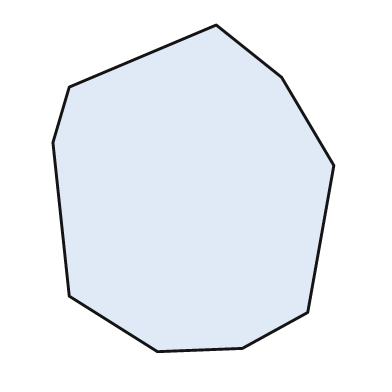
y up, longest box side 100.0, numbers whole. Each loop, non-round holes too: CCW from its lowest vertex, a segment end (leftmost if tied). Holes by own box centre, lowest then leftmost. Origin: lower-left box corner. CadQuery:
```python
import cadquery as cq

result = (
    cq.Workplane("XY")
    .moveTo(32.0, 0.0)
    .lineTo(58.0, 1.0)
    .lineTo(78.0, 12.0)
    .lineTo(86.0, 57.0)
    .lineTo(70.0, 84.0)
    .lineTo(50.0, 100.0)
    .lineTo(5.0, 81.0)
    .lineTo(0.0, 64.0)
    .lineTo(5.0, 17.0)
    .close()
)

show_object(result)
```